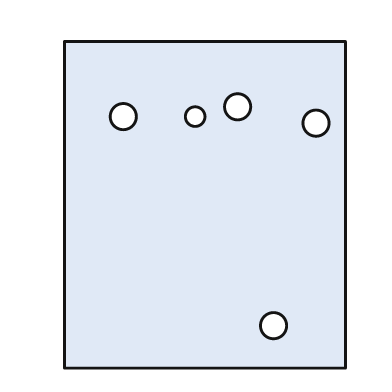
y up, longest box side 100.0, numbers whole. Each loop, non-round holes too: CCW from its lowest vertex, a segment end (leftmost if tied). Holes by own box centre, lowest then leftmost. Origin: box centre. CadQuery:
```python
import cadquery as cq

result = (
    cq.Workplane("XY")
    .moveTo(-43.0, -50.0)
    .lineTo(43.0, -50.0)
    .lineTo(43.0, 50.0)
    .lineTo(-43.0, 50.0)
    .close()
    .moveTo(21.0, -37.0)
    .circle(4.0)
    .moveTo(34.0, 25.0)
    .circle(4.0)
    .moveTo(-25.0, 27.0)
    .circle(4.0)
    .moveTo(-3.0, 27.0)
    .circle(3.0)
    .moveTo(10.0, 30.0)
    .circle(4.0)
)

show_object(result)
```